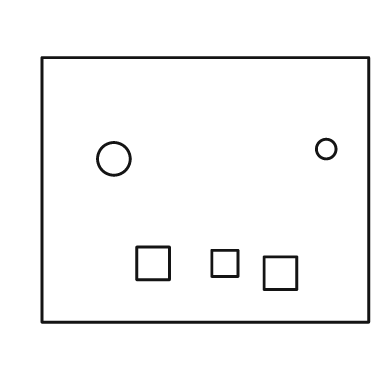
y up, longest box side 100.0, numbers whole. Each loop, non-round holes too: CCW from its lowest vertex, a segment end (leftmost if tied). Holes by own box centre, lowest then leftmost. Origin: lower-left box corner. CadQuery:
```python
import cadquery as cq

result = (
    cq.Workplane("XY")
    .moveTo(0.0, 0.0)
    .lineTo(100.0, 0.0)
    .lineTo(100.0, 81.0)
    .lineTo(0.0, 81.0)
    .close()
    .moveTo(68.0, 10.0)
    .lineTo(78.0, 10.0)
    .lineTo(78.0, 20.0)
    .lineTo(68.0, 20.0)
    .close()
    .moveTo(29.0, 13.0)
    .lineTo(39.0, 13.0)
    .lineTo(39.0, 23.0)
    .lineTo(29.0, 23.0)
    .close()
    .moveTo(52.0, 14.0)
    .lineTo(60.0, 14.0)
    .lineTo(60.0, 22.0)
    .lineTo(52.0, 22.0)
    .close()
    .moveTo(22.0, 50.0)
    .circle(5.0)
    .moveTo(87.0, 53.0)
    .circle(3.0)
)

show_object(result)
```